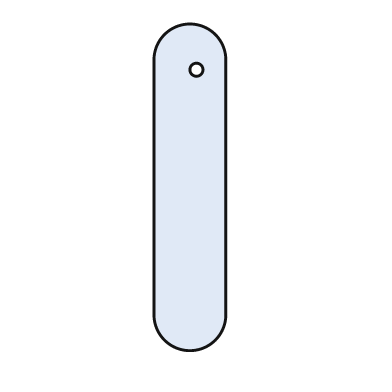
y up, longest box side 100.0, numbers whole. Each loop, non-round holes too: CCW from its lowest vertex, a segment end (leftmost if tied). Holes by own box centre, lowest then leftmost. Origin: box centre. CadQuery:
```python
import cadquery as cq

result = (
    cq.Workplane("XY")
    .moveTo(-11.0, -39.0)
    .threePointArc((0.0, -50.0), (11.0, -39.0))
    .lineTo(11.0, 39.0)
    .threePointArc((0.0, 50.0), (-11.0, 39.0))
    .close()
    .moveTo(2.0, 36.0)
    .circle(2.0)
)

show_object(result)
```